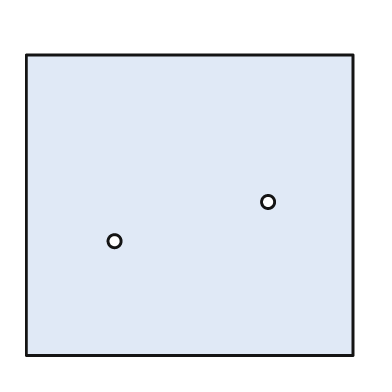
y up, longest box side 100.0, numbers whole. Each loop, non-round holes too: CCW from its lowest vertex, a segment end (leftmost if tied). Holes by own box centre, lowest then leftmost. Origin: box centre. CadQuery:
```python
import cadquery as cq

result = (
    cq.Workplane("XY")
    .moveTo(-50.0, -46.0)
    .lineTo(50.0, -46.0)
    .lineTo(50.0, 46.0)
    .lineTo(-50.0, 46.0)
    .close()
    .moveTo(-23.0, -11.0)
    .circle(2.0)
    .moveTo(24.0, 1.0)
    .circle(2.0)
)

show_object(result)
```